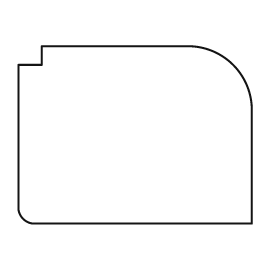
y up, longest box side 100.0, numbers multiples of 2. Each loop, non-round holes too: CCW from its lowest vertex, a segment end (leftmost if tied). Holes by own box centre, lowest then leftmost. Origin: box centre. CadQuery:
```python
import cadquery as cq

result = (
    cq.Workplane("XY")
    .moveTo(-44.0, -38.0)
    .lineTo(50.0, -38.0)
    .lineTo(50.0, 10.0)
    .threePointArc((42.0, 30.0), (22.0, 38.0))
    .lineTo(-40.0, 38.0)
    .lineTo(-40.0, 30.0)
    .lineTo(-50.0, 30.0)
    .lineTo(-50.0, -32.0)
    .threePointArc((-48.0, -36.0), (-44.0, -38.0))
    .close()
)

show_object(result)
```